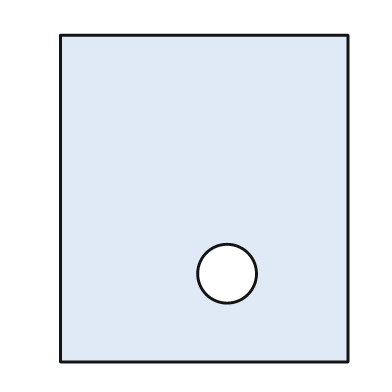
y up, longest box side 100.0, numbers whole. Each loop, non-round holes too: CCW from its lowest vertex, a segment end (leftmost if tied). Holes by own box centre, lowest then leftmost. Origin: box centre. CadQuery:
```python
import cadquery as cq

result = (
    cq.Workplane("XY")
    .moveTo(-44.0, -50.0)
    .lineTo(44.0, -50.0)
    .lineTo(44.0, 50.0)
    .lineTo(-44.0, 50.0)
    .close()
    .moveTo(7.0, -23.0)
    .circle(9.0)
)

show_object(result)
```